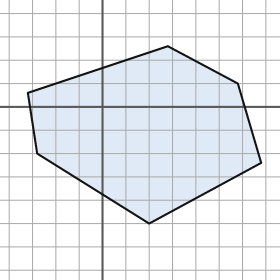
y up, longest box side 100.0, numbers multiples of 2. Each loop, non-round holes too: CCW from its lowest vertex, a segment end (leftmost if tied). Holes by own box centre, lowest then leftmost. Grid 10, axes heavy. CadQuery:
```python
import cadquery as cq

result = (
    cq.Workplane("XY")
    .moveTo(20.0, -50.0)
    .lineTo(68.0, -24.0)
    .lineTo(58.0, 10.0)
    .lineTo(28.0, 26.0)
    .lineTo(-32.0, 6.0)
    .lineTo(-28.0, -20.0)
    .close()
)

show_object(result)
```